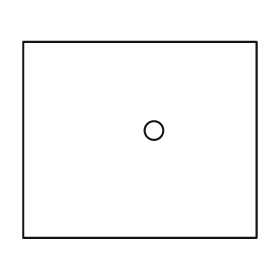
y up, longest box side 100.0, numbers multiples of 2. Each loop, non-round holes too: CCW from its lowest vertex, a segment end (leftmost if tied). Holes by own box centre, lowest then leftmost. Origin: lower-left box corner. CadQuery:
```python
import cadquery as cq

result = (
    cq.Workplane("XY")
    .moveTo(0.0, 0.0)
    .lineTo(100.0, 0.0)
    .lineTo(100.0, 84.0)
    .lineTo(0.0, 84.0)
    .close()
    .moveTo(56.0, 46.0)
    .circle(4.0)
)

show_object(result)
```